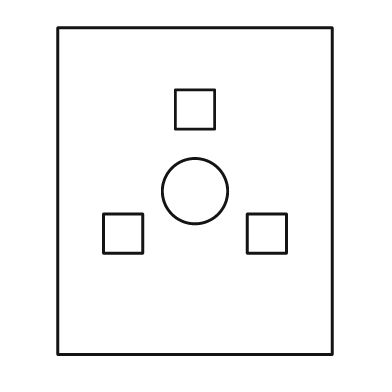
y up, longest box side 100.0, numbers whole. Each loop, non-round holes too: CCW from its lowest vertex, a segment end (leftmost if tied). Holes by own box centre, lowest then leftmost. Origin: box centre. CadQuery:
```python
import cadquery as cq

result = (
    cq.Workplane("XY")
    .moveTo(-42.0, -50.0)
    .lineTo(42.0, -50.0)
    .lineTo(42.0, 50.0)
    .lineTo(-42.0, 50.0)
    .close()
    .moveTo(-28.0, -19.0)
    .lineTo(-16.0, -19.0)
    .lineTo(-16.0, -7.0)
    .lineTo(-28.0, -7.0)
    .close()
    .moveTo(16.0, -19.0)
    .lineTo(28.0, -19.0)
    .lineTo(28.0, -7.0)
    .lineTo(16.0, -7.0)
    .close()
    .moveTo(0.0, 0.0)
    .circle(10.0)
    .moveTo(-6.0, 19.0)
    .lineTo(6.0, 19.0)
    .lineTo(6.0, 31.0)
    .lineTo(-6.0, 31.0)
    .close()
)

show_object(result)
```